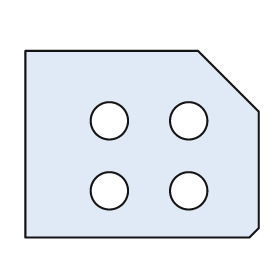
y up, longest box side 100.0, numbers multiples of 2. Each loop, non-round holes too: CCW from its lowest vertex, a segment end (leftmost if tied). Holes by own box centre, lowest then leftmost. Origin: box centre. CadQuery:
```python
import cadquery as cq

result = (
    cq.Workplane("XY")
    .moveTo(-50.0, -40.0)
    .lineTo(46.0, -40.0)
    .lineTo(50.0, -36.0)
    .lineTo(50.0, 14.0)
    .lineTo(24.0, 40.0)
    .lineTo(-50.0, 40.0)
    .close()
    .moveTo(-14.0, -20.0)
    .circle(8.0)
    .moveTo(20.0, -20.0)
    .circle(8.0)
    .moveTo(-14.0, 10.0)
    .circle(8.0)
    .moveTo(20.0, 10.0)
    .circle(8.0)
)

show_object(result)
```